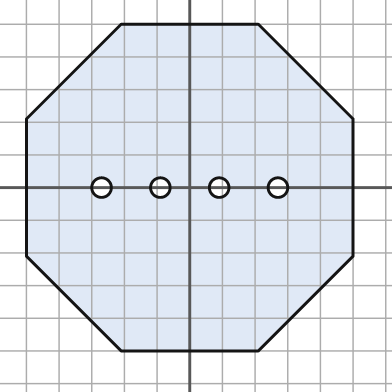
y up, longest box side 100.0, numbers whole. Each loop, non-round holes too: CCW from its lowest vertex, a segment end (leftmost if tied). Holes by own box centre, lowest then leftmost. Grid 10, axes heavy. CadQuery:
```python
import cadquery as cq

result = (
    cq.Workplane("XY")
    .moveTo(-21.0, -50.0)
    .lineTo(21.0, -50.0)
    .lineTo(50.0, -21.0)
    .lineTo(50.0, 21.0)
    .lineTo(21.0, 50.0)
    .lineTo(-21.0, 50.0)
    .lineTo(-50.0, 21.0)
    .lineTo(-50.0, -21.0)
    .close()
    .moveTo(-27.0, 0.0)
    .circle(3.0)
    .moveTo(-9.0, 0.0)
    .circle(3.0)
    .moveTo(9.0, 0.0)
    .circle(3.0)
    .moveTo(27.0, 0.0)
    .circle(3.0)
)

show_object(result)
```